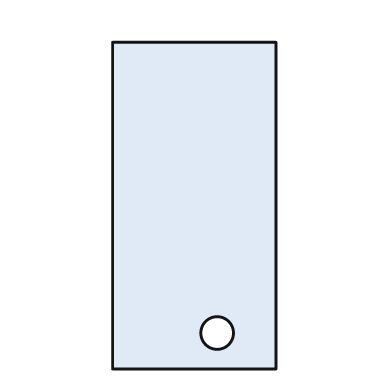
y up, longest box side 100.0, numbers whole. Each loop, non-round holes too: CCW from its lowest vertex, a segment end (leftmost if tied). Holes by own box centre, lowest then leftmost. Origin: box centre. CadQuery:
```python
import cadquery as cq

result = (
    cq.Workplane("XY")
    .moveTo(-25.0, -50.0)
    .lineTo(25.0, -50.0)
    .lineTo(25.0, 50.0)
    .lineTo(-25.0, 50.0)
    .close()
    .moveTo(7.0, -39.0)
    .circle(5.0)
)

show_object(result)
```